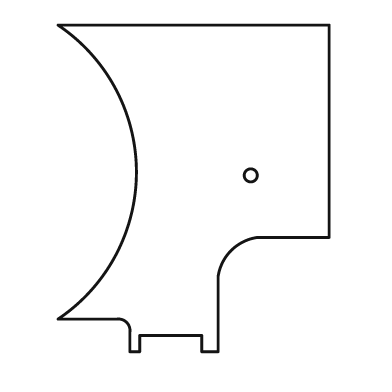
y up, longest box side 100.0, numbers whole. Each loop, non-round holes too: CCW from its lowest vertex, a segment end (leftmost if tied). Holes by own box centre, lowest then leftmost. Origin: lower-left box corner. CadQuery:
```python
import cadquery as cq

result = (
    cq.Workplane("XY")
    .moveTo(22.0, 0.0)
    .lineTo(25.0, 0.0)
    .lineTo(25.0, 5.0)
    .lineTo(44.0, 5.0)
    .lineTo(44.0, 0.0)
    .lineTo(49.0, 0.0)
    .lineTo(49.0, 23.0)
    .threePointArc((53.0, 31.0), (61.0, 35.0))
    .lineTo(83.0, 35.0)
    .lineTo(83.0, 100.0)
    .lineTo(0.0, 100.0)
    .threePointArc((24.0, 55.0), (0.0, 10.0))
    .lineTo(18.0, 10.0)
    .threePointArc((21.0, 9.0), (22.0, 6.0))
    .close()
    .moveTo(59.0, 54.0)
    .circle(2.0)
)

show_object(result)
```